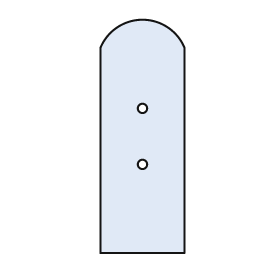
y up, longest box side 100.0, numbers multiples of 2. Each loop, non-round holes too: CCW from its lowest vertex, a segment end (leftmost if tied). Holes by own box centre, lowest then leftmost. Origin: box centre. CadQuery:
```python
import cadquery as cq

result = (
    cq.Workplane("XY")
    .moveTo(-18.0, -50.0)
    .lineTo(18.0, -50.0)
    .lineTo(18.0, 38.0)
    .threePointArc((0.0, 50.0), (-18.0, 38.0))
    .close()
    .moveTo(0.0, -12.0)
    .circle(2.0)
    .moveTo(0.0, 12.0)
    .circle(2.0)
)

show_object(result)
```